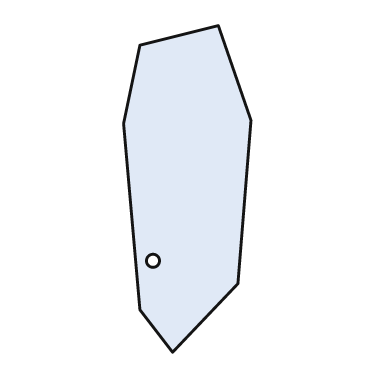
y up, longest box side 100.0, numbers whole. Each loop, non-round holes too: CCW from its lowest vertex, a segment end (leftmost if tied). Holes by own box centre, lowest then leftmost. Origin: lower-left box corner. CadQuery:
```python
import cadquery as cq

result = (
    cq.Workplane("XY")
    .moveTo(15.0, 0.0)
    .lineTo(35.0, 21.0)
    .lineTo(39.0, 71.0)
    .lineTo(29.0, 100.0)
    .lineTo(5.0, 94.0)
    .lineTo(0.0, 70.0)
    .lineTo(5.0, 13.0)
    .close()
    .moveTo(9.0, 28.0)
    .circle(2.0)
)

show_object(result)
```